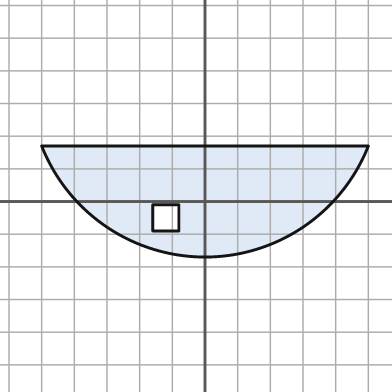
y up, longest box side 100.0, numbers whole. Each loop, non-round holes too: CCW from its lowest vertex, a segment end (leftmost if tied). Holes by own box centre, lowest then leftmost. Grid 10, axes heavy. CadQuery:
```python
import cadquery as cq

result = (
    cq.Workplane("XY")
    .moveTo(-50.0, 17.0)
    .threePointArc((0.0, -17.0), (50.0, 17.0))
    .close()
    .moveTo(-16.0, -9.0)
    .lineTo(-8.0, -9.0)
    .lineTo(-8.0, -1.0)
    .lineTo(-16.0, -1.0)
    .close()
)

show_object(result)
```